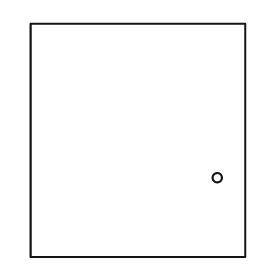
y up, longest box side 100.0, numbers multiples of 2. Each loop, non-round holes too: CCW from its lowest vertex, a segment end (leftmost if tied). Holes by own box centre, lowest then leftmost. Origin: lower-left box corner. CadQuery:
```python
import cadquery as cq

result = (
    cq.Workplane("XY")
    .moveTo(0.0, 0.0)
    .lineTo(92.0, 0.0)
    .lineTo(92.0, 100.0)
    .lineTo(0.0, 100.0)
    .close()
    .moveTo(80.0, 34.0)
    .circle(2.0)
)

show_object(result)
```